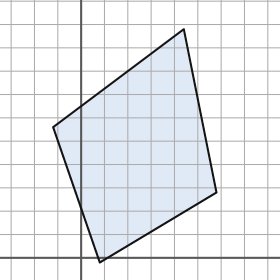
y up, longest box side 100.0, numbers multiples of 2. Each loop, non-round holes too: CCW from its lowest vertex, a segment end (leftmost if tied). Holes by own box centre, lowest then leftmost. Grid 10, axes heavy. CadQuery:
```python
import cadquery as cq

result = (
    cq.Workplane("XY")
    .moveTo(8.0, -2.0)
    .lineTo(58.0, 28.0)
    .lineTo(44.0, 98.0)
    .lineTo(-12.0, 56.0)
    .close()
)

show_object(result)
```